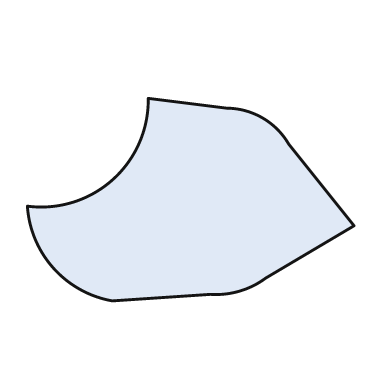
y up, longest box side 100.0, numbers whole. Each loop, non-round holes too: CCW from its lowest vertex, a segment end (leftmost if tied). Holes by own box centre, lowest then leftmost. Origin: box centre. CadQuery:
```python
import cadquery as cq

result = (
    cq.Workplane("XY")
    .moveTo(-24.0, -31.0)
    .lineTo(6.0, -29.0)
    .threePointArc((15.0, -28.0), (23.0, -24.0))
    .lineTo(50.0, -8.0)
    .lineTo(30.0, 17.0)
    .threePointArc((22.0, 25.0), (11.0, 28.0))
    .lineTo(-13.0, 31.0)
    .threePointArc((-24.0, 6.0), (-50.0, -2.0))
    .threePointArc((-42.0, -21.0), (-24.0, -31.0))
    .close()
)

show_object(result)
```